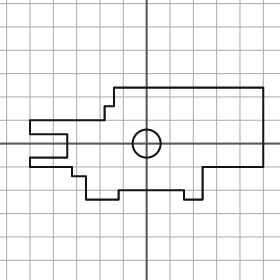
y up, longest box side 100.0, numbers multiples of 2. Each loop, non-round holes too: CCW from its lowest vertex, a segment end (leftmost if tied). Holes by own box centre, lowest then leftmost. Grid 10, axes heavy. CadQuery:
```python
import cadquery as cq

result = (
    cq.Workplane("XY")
    .moveTo(-26.0, -24.0)
    .lineTo(-12.0, -24.0)
    .lineTo(-12.0, -20.0)
    .lineTo(16.0, -20.0)
    .lineTo(16.0, -24.0)
    .lineTo(24.0, -24.0)
    .lineTo(24.0, -10.0)
    .lineTo(50.0, -10.0)
    .lineTo(50.0, 24.0)
    .lineTo(-14.0, 24.0)
    .lineTo(-14.0, 16.0)
    .lineTo(-18.0, 16.0)
    .lineTo(-18.0, 10.0)
    .lineTo(-50.0, 10.0)
    .lineTo(-50.0, 4.0)
    .lineTo(-34.0, 4.0)
    .lineTo(-34.0, -6.0)
    .lineTo(-50.0, -6.0)
    .lineTo(-50.0, -10.0)
    .lineTo(-32.0, -10.0)
    .lineTo(-32.0, -14.0)
    .lineTo(-26.0, -14.0)
    .close()
    .moveTo(0.0, 0.0)
    .circle(6.0)
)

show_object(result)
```